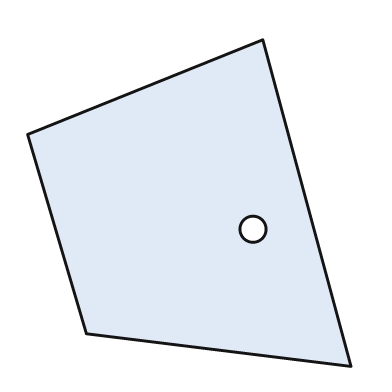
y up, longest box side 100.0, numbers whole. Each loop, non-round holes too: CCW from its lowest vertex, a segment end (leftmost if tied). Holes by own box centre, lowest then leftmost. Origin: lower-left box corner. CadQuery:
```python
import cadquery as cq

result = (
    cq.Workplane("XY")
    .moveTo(99.0, 0.0)
    .lineTo(72.0, 100.0)
    .lineTo(0.0, 71.0)
    .lineTo(18.0, 10.0)
    .close()
    .moveTo(69.0, 42.0)
    .circle(4.0)
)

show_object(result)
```